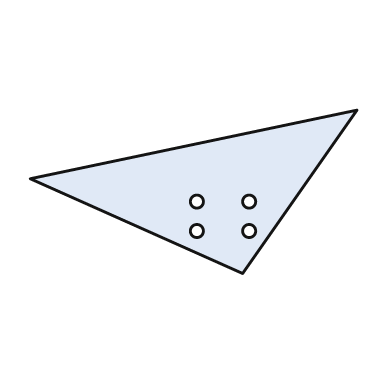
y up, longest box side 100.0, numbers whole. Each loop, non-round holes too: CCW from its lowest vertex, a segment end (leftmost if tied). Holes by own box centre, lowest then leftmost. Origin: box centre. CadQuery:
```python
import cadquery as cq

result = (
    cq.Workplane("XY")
    .moveTo(15.0, -25.0)
    .lineTo(50.0, 25.0)
    .lineTo(-50.0, 4.0)
    .close()
    .moveTo(1.0, -12.0)
    .circle(2.0)
    .moveTo(17.0, -12.0)
    .circle(2.0)
    .moveTo(1.0, -3.0)
    .circle(2.0)
    .moveTo(17.0, -3.0)
    .circle(2.0)
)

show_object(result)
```